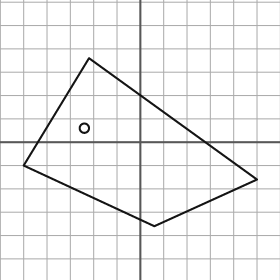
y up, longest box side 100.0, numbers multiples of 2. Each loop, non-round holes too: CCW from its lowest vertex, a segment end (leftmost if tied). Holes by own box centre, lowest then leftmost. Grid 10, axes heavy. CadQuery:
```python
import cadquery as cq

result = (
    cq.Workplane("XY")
    .moveTo(6.0, -36.0)
    .lineTo(50.0, -16.0)
    .lineTo(-22.0, 36.0)
    .lineTo(-50.0, -10.0)
    .close()
    .moveTo(-24.0, 6.0)
    .circle(2.0)
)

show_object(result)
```